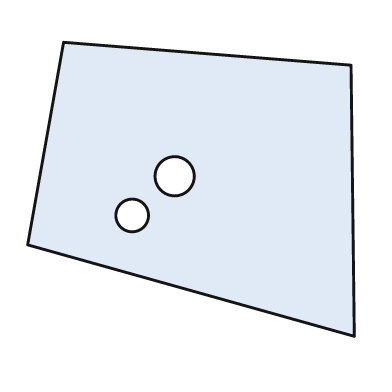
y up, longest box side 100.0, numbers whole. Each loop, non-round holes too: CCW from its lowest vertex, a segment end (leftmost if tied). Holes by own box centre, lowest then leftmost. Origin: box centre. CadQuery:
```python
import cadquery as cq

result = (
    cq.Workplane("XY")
    .moveTo(50.0, -45.0)
    .lineTo(49.0, 38.0)
    .lineTo(-39.0, 45.0)
    .lineTo(-50.0, -17.0)
    .close()
    .moveTo(-18.0, -8.0)
    .circle(5.0)
    .moveTo(-5.0, 4.0)
    .circle(6.0)
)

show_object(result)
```